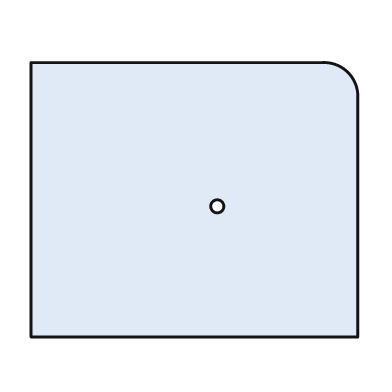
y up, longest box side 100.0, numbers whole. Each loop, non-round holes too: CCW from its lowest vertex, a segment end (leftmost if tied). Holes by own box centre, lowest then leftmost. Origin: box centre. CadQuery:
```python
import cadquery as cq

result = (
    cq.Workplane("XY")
    .moveTo(-50.0, -42.0)
    .lineTo(50.0, -42.0)
    .lineTo(50.0, 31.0)
    .threePointArc((47.0, 39.0), (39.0, 42.0))
    .lineTo(-50.0, 42.0)
    .close()
    .moveTo(7.0, -2.0)
    .circle(2.0)
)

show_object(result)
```